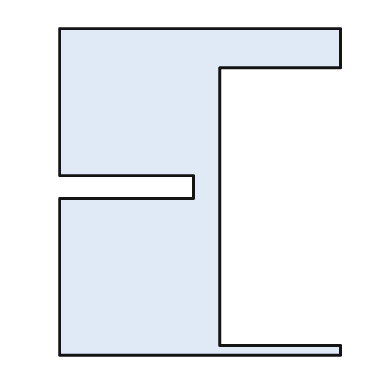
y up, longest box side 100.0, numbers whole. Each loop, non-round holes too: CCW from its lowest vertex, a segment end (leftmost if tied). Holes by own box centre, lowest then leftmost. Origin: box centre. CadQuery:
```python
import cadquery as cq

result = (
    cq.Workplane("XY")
    .moveTo(-43.0, -50.0)
    .lineTo(43.0, -50.0)
    .lineTo(43.0, -47.0)
    .lineTo(6.0, -47.0)
    .lineTo(6.0, 38.0)
    .lineTo(43.0, 38.0)
    .lineTo(43.0, 50.0)
    .lineTo(-43.0, 50.0)
    .lineTo(-43.0, 5.0)
    .lineTo(-2.0, 5.0)
    .lineTo(-2.0, -2.0)
    .lineTo(-43.0, -2.0)
    .close()
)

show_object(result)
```